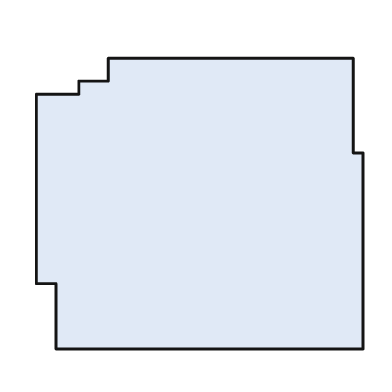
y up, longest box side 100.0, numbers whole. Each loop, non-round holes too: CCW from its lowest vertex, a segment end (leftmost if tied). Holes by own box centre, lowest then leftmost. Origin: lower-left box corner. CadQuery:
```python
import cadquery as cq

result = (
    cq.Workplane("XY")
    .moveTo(6.0, 0.0)
    .lineTo(100.0, 0.0)
    .lineTo(100.0, 60.0)
    .lineTo(97.0, 60.0)
    .lineTo(97.0, 89.0)
    .lineTo(22.0, 89.0)
    .lineTo(22.0, 82.0)
    .lineTo(13.0, 82.0)
    .lineTo(13.0, 78.0)
    .lineTo(0.0, 78.0)
    .lineTo(0.0, 20.0)
    .lineTo(6.0, 20.0)
    .close()
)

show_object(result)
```